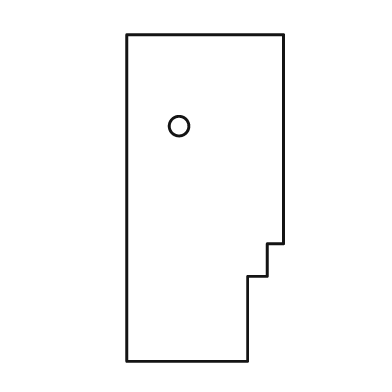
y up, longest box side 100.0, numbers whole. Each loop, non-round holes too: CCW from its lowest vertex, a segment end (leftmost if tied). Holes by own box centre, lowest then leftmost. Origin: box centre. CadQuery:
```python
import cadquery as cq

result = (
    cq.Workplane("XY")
    .moveTo(-24.0, -50.0)
    .lineTo(13.0, -50.0)
    .lineTo(13.0, -24.0)
    .lineTo(19.0, -24.0)
    .lineTo(19.0, -14.0)
    .lineTo(24.0, -14.0)
    .lineTo(24.0, 50.0)
    .lineTo(-24.0, 50.0)
    .close()
    .moveTo(-8.0, 22.0)
    .circle(3.0)
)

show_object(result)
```